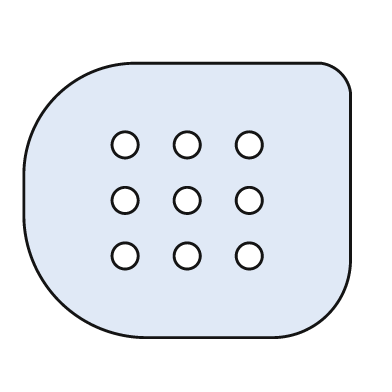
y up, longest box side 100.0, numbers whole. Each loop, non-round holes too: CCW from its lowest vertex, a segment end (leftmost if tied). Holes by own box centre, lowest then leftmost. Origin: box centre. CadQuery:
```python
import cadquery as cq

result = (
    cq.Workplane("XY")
    .moveTo(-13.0, -42.0)
    .lineTo(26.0, -42.0)
    .threePointArc((43.0, -35.0), (50.0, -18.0))
    .lineTo(50.0, 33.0)
    .threePointArc((47.0, 39.0), (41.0, 42.0))
    .lineTo(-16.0, 42.0)
    .threePointArc((-40.0, 32.0), (-50.0, 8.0))
    .lineTo(-50.0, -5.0)
    .threePointArc((-39.0, -31.0), (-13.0, -42.0))
    .close()
    .moveTo(-19.0, -17.0)
    .circle(4.0)
    .moveTo(0.0, -17.0)
    .circle(4.0)
    .moveTo(19.0, -17.0)
    .circle(4.0)
    .moveTo(-19.0, 0.0)
    .circle(4.0)
    .moveTo(0.0, 0.0)
    .circle(4.0)
    .moveTo(19.0, 0.0)
    .circle(4.0)
    .moveTo(-19.0, 17.0)
    .circle(4.0)
    .moveTo(0.0, 17.0)
    .circle(4.0)
    .moveTo(19.0, 17.0)
    .circle(4.0)
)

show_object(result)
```